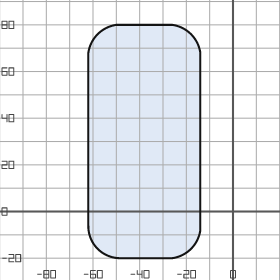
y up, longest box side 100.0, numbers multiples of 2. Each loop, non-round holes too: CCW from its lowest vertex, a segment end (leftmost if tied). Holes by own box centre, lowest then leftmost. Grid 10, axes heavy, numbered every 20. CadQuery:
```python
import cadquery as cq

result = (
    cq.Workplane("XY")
    .moveTo(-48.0, -20.0)
    .lineTo(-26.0, -20.0)
    .threePointArc((-18.0, -16.0), (-14.0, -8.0))
    .lineTo(-14.0, 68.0)
    .threePointArc((-18.0, 76.0), (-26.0, 80.0))
    .lineTo(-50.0, 80.0)
    .threePointArc((-58.0, 76.0), (-62.0, 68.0))
    .lineTo(-62.0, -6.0)
    .threePointArc((-58.0, -16.0), (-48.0, -20.0))
    .close()
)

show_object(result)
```